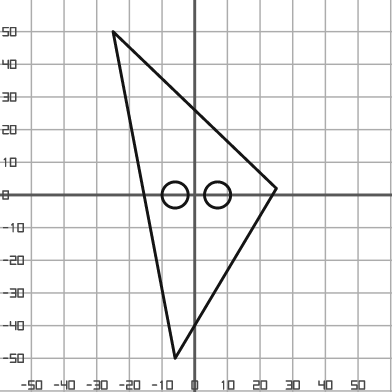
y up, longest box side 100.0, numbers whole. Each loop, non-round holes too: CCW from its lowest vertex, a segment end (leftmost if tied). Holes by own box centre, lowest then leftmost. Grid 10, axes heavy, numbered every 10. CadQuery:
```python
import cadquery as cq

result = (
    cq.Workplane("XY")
    .moveTo(-6.0, -50.0)
    .lineTo(25.0, 2.0)
    .lineTo(-25.0, 50.0)
    .close()
    .moveTo(-6.0, 0.0)
    .circle(4.0)
    .moveTo(7.0, 0.0)
    .circle(4.0)
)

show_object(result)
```